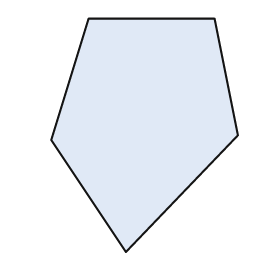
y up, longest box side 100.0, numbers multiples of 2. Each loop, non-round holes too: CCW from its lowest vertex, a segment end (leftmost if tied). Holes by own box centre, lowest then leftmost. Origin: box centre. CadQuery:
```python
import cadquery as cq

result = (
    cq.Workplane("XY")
    .moveTo(-8.0, -50.0)
    .lineTo(40.0, 0.0)
    .lineTo(30.0, 50.0)
    .lineTo(-24.0, 50.0)
    .lineTo(-40.0, -2.0)
    .close()
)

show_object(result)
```